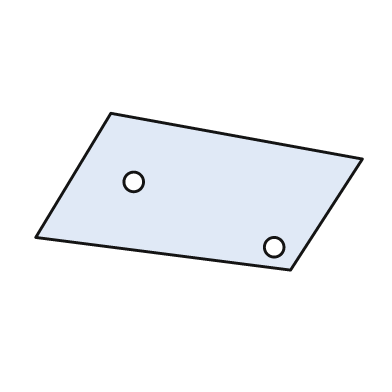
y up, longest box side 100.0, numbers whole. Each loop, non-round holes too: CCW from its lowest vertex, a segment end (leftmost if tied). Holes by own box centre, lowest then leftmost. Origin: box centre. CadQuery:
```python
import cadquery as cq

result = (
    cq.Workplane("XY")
    .moveTo(28.0, -24.0)
    .lineTo(50.0, 10.0)
    .lineTo(-27.0, 24.0)
    .lineTo(-50.0, -14.0)
    .close()
    .moveTo(23.0, -17.0)
    .circle(3.0)
    .moveTo(-20.0, 3.0)
    .circle(3.0)
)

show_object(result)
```